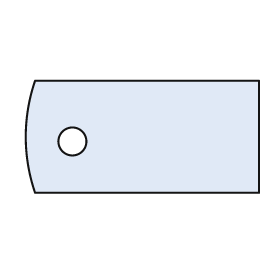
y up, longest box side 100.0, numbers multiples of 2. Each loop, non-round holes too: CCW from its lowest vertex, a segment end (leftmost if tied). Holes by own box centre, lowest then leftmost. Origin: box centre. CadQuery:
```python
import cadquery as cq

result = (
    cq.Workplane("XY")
    .moveTo(-46.0, -24.0)
    .lineTo(50.0, -24.0)
    .lineTo(50.0, 24.0)
    .lineTo(-46.0, 24.0)
    .threePointArc((-50.0, 0.0), (-46.0, -24.0))
    .close()
    .moveTo(-30.0, -2.0)
    .circle(6.0)
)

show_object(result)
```